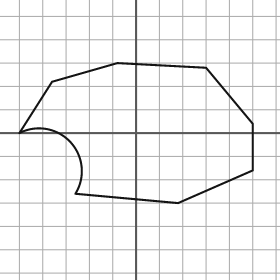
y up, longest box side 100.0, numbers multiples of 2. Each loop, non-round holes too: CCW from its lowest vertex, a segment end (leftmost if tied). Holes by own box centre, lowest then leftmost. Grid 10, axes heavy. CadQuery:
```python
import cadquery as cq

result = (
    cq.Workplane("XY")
    .moveTo(18.0, -30.0)
    .lineTo(50.0, -16.0)
    .lineTo(50.0, 4.0)
    .lineTo(30.0, 28.0)
    .lineTo(-8.0, 30.0)
    .lineTo(-36.0, 22.0)
    .lineTo(-50.0, 0.0)
    .threePointArc((-28.0, -4.0), (-26.0, -26.0))
    .close()
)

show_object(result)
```